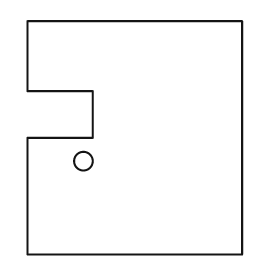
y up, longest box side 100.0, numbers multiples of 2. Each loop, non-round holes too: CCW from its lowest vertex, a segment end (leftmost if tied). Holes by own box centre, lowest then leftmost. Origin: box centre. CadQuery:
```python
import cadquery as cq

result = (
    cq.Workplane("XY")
    .moveTo(-46.0, -50.0)
    .lineTo(46.0, -50.0)
    .lineTo(46.0, 50.0)
    .lineTo(-46.0, 50.0)
    .lineTo(-46.0, 20.0)
    .lineTo(-18.0, 20.0)
    .lineTo(-18.0, 0.0)
    .lineTo(-46.0, 0.0)
    .close()
    .moveTo(-22.0, -10.0)
    .circle(4.0)
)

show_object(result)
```